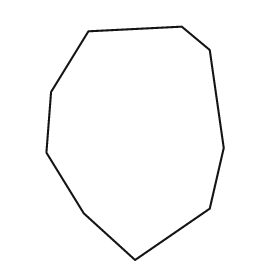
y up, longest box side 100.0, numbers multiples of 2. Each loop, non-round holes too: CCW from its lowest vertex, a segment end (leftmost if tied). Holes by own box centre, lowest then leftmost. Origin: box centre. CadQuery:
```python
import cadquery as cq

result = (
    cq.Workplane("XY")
    .moveTo(0.0, -50.0)
    .lineTo(32.0, -28.0)
    .lineTo(38.0, -2.0)
    .lineTo(32.0, 40.0)
    .lineTo(20.0, 50.0)
    .lineTo(-20.0, 48.0)
    .lineTo(-36.0, 22.0)
    .lineTo(-38.0, -4.0)
    .lineTo(-22.0, -30.0)
    .close()
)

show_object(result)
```